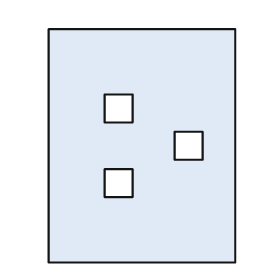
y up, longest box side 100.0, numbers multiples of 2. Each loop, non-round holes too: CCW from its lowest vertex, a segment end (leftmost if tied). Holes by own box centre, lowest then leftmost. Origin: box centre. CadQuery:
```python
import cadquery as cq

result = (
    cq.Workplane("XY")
    .moveTo(-40.0, -50.0)
    .lineTo(40.0, -50.0)
    .lineTo(40.0, 50.0)
    .lineTo(-40.0, 50.0)
    .close()
    .moveTo(-16.0, -22.0)
    .lineTo(-4.0, -22.0)
    .lineTo(-4.0, -10.0)
    .lineTo(-16.0, -10.0)
    .close()
    .moveTo(14.0, -6.0)
    .lineTo(26.0, -6.0)
    .lineTo(26.0, 6.0)
    .lineTo(14.0, 6.0)
    .close()
    .moveTo(-16.0, 10.0)
    .lineTo(-4.0, 10.0)
    .lineTo(-4.0, 22.0)
    .lineTo(-16.0, 22.0)
    .close()
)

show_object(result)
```